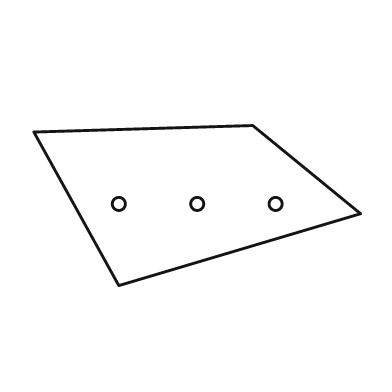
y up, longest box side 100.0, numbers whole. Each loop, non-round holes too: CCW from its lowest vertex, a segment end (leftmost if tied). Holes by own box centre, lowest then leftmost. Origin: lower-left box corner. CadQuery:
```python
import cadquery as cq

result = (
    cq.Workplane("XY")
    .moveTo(26.0, 0.0)
    .lineTo(100.0, 22.0)
    .lineTo(67.0, 49.0)
    .lineTo(0.0, 47.0)
    .close()
    .moveTo(26.0, 25.0)
    .circle(2.0)
    .moveTo(50.0, 25.0)
    .circle(2.0)
    .moveTo(74.0, 25.0)
    .circle(2.0)
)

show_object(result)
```